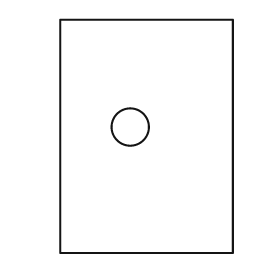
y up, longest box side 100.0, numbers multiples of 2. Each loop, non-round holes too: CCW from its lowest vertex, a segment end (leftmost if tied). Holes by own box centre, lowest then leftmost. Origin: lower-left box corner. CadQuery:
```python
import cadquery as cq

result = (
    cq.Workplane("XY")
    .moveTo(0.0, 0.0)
    .lineTo(74.0, 0.0)
    .lineTo(74.0, 100.0)
    .lineTo(0.0, 100.0)
    .close()
    .moveTo(30.0, 54.0)
    .circle(8.0)
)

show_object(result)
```